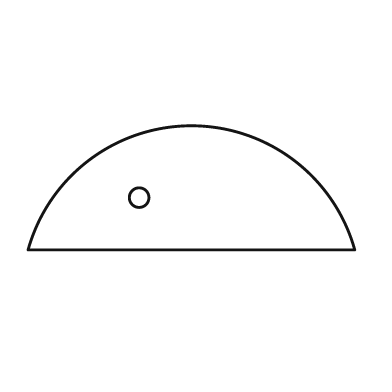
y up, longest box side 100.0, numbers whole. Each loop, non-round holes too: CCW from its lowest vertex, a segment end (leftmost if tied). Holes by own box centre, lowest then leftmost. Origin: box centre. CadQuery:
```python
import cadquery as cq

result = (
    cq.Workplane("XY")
    .moveTo(-50.0, -19.0)
    .lineTo(50.0, -19.0)
    .threePointArc((0.0, 19.0), (-50.0, -19.0))
    .close()
    .moveTo(-16.0, -3.0)
    .circle(3.0)
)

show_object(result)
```